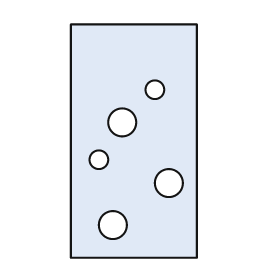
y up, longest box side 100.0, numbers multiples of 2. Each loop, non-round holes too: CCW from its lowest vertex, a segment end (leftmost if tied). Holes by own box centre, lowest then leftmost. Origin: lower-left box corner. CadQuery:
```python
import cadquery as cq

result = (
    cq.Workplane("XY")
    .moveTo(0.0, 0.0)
    .lineTo(54.0, 0.0)
    .lineTo(54.0, 100.0)
    .lineTo(0.0, 100.0)
    .close()
    .moveTo(18.0, 14.0)
    .circle(6.0)
    .moveTo(42.0, 32.0)
    .circle(6.0)
    .moveTo(12.0, 42.0)
    .circle(4.0)
    .moveTo(22.0, 58.0)
    .circle(6.0)
    .moveTo(36.0, 72.0)
    .circle(4.0)
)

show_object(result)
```